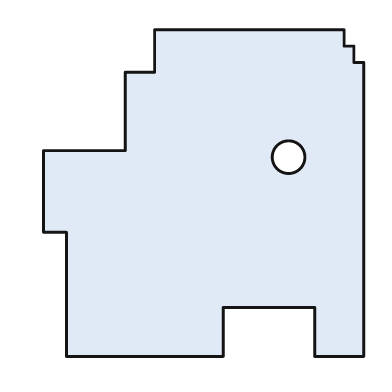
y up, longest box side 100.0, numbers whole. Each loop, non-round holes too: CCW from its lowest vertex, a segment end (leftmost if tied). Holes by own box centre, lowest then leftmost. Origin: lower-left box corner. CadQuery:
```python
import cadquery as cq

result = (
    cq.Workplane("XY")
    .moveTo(7.0, 0.0)
    .lineTo(55.0, 0.0)
    .lineTo(55.0, 15.0)
    .lineTo(83.0, 15.0)
    .lineTo(83.0, 0.0)
    .lineTo(98.0, 0.0)
    .lineTo(98.0, 90.0)
    .lineTo(95.0, 90.0)
    .lineTo(95.0, 95.0)
    .lineTo(92.0, 95.0)
    .lineTo(92.0, 100.0)
    .lineTo(34.0, 100.0)
    .lineTo(34.0, 87.0)
    .lineTo(25.0, 87.0)
    .lineTo(25.0, 63.0)
    .lineTo(0.0, 63.0)
    .lineTo(0.0, 38.0)
    .lineTo(7.0, 38.0)
    .close()
    .moveTo(75.0, 61.0)
    .circle(5.0)
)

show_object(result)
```